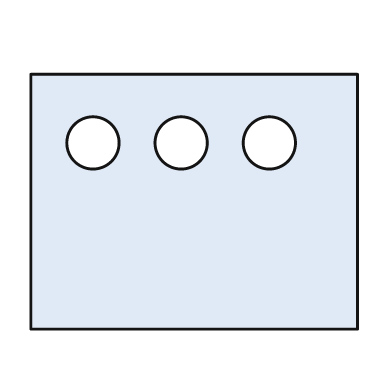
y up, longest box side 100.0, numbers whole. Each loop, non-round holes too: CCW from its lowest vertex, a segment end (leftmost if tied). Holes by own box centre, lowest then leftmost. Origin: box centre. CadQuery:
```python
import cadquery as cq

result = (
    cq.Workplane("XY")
    .moveTo(-50.0, -39.0)
    .lineTo(50.0, -39.0)
    .lineTo(50.0, 39.0)
    .lineTo(-50.0, 39.0)
    .close()
    .moveTo(-31.0, 18.0)
    .circle(8.0)
    .moveTo(-4.0, 18.0)
    .circle(8.0)
    .moveTo(23.0, 18.0)
    .circle(8.0)
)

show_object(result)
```